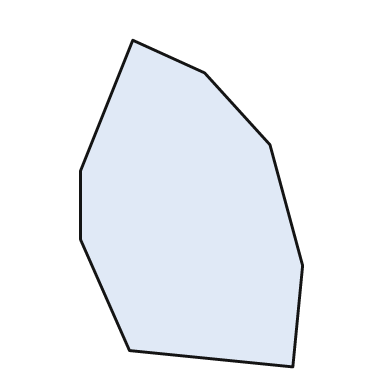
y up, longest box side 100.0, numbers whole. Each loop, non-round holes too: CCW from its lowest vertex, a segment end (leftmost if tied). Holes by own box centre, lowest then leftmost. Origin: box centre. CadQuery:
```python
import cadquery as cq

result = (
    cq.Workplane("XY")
    .moveTo(31.0, -50.0)
    .lineTo(34.0, -19.0)
    .lineTo(24.0, 18.0)
    .lineTo(4.0, 40.0)
    .lineTo(-18.0, 50.0)
    .lineTo(-34.0, 10.0)
    .lineTo(-34.0, -11.0)
    .lineTo(-19.0, -45.0)
    .close()
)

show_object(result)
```